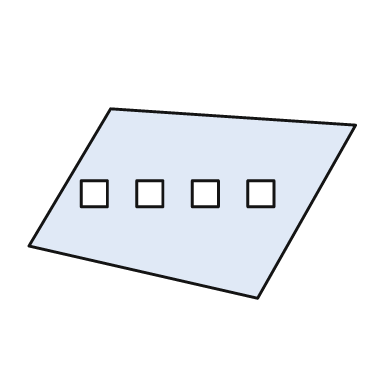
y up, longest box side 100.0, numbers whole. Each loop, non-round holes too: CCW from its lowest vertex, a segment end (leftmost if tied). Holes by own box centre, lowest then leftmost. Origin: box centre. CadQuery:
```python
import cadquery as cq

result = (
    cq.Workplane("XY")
    .moveTo(20.0, -29.0)
    .lineTo(50.0, 24.0)
    .lineTo(-25.0, 29.0)
    .lineTo(-50.0, -13.0)
    .close()
    .moveTo(-34.0, -1.0)
    .lineTo(-26.0, -1.0)
    .lineTo(-26.0, 7.0)
    .lineTo(-34.0, 7.0)
    .close()
    .moveTo(-17.0, -1.0)
    .lineTo(-9.0, -1.0)
    .lineTo(-9.0, 7.0)
    .lineTo(-17.0, 7.0)
    .close()
    .moveTo(0.0, -1.0)
    .lineTo(8.0, -1.0)
    .lineTo(8.0, 7.0)
    .lineTo(0.0, 7.0)
    .close()
    .moveTo(17.0, -1.0)
    .lineTo(25.0, -1.0)
    .lineTo(25.0, 7.0)
    .lineTo(17.0, 7.0)
    .close()
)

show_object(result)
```